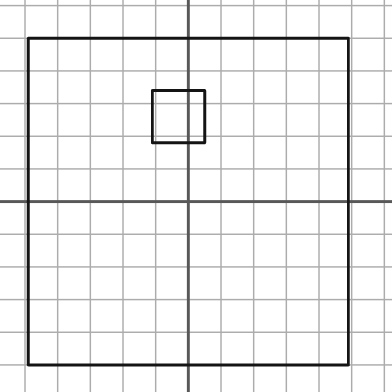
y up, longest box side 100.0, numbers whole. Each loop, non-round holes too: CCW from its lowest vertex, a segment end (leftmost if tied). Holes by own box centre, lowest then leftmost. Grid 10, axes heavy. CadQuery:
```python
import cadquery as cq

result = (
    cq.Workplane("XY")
    .moveTo(-49.0, -50.0)
    .lineTo(49.0, -50.0)
    .lineTo(49.0, 50.0)
    .lineTo(-49.0, 50.0)
    .close()
    .moveTo(-11.0, 18.0)
    .lineTo(5.0, 18.0)
    .lineTo(5.0, 34.0)
    .lineTo(-11.0, 34.0)
    .close()
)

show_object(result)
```